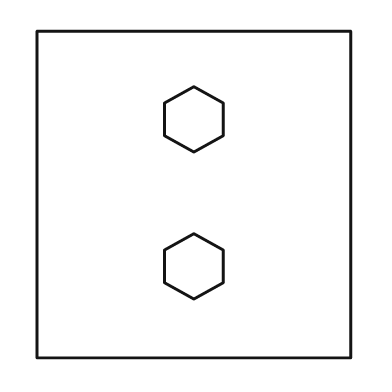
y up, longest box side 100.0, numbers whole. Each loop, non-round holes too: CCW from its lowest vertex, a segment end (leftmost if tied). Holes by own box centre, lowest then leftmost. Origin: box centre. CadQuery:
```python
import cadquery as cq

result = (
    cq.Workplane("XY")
    .moveTo(-48.0, -50.0)
    .lineTo(48.0, -50.0)
    .lineTo(48.0, 50.0)
    .lineTo(-48.0, 50.0)
    .close()
    .moveTo(0.0, -32.0)
    .lineTo(9.0, -27.0)
    .lineTo(9.0, -17.0)
    .lineTo(0.0, -12.0)
    .lineTo(-9.0, -17.0)
    .lineTo(-9.0, -27.0)
    .close()
    .moveTo(0.0, 13.0)
    .lineTo(9.0, 18.0)
    .lineTo(9.0, 28.0)
    .lineTo(0.0, 33.0)
    .lineTo(-9.0, 28.0)
    .lineTo(-9.0, 18.0)
    .close()
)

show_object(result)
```